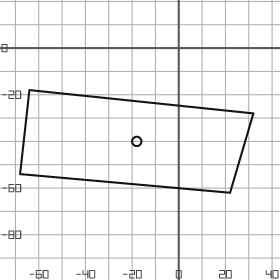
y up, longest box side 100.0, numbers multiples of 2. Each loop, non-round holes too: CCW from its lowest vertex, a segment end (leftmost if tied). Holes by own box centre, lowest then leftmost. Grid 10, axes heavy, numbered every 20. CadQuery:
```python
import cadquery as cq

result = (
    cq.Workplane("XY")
    .moveTo(22.0, -62.0)
    .lineTo(32.0, -28.0)
    .lineTo(-64.0, -18.0)
    .lineTo(-68.0, -54.0)
    .close()
    .moveTo(-18.0, -40.0)
    .circle(2.0)
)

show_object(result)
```